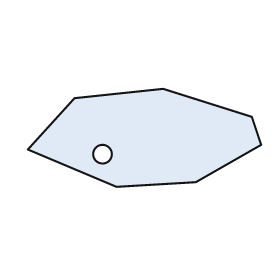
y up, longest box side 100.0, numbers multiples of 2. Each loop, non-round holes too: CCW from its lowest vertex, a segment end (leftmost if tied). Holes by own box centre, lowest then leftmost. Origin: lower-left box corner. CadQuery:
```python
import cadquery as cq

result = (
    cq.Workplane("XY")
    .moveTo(38.0, 0.0)
    .lineTo(72.0, 2.0)
    .lineTo(100.0, 18.0)
    .lineTo(96.0, 30.0)
    .lineTo(58.0, 42.0)
    .lineTo(20.0, 38.0)
    .lineTo(0.0, 16.0)
    .close()
    .moveTo(32.0, 14.0)
    .circle(4.0)
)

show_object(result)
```